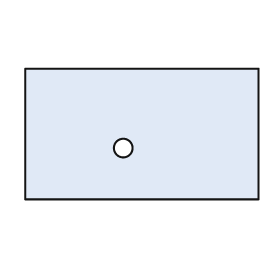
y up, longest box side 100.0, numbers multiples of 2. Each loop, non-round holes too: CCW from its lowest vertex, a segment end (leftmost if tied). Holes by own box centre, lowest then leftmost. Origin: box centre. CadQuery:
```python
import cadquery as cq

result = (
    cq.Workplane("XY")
    .moveTo(-50.0, -28.0)
    .lineTo(50.0, -28.0)
    .lineTo(50.0, 28.0)
    .lineTo(-50.0, 28.0)
    .close()
    .moveTo(-8.0, -6.0)
    .circle(4.0)
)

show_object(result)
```